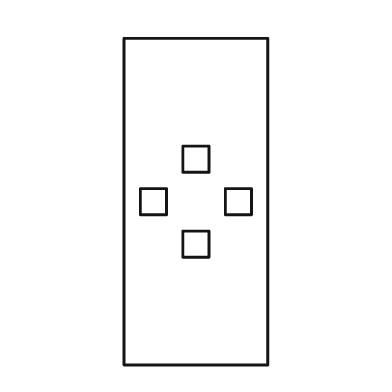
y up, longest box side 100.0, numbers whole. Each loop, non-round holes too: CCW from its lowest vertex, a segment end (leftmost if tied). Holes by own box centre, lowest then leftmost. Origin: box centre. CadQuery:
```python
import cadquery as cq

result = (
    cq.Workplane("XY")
    .moveTo(-22.0, -50.0)
    .lineTo(22.0, -50.0)
    .lineTo(22.0, 50.0)
    .lineTo(-22.0, 50.0)
    .close()
    .moveTo(-4.0, -17.0)
    .lineTo(4.0, -17.0)
    .lineTo(4.0, -9.0)
    .lineTo(-4.0, -9.0)
    .close()
    .moveTo(-17.0, -4.0)
    .lineTo(-9.0, -4.0)
    .lineTo(-9.0, 4.0)
    .lineTo(-17.0, 4.0)
    .close()
    .moveTo(9.0, -4.0)
    .lineTo(17.0, -4.0)
    .lineTo(17.0, 4.0)
    .lineTo(9.0, 4.0)
    .close()
    .moveTo(-4.0, 9.0)
    .lineTo(4.0, 9.0)
    .lineTo(4.0, 17.0)
    .lineTo(-4.0, 17.0)
    .close()
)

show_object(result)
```